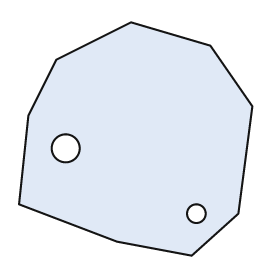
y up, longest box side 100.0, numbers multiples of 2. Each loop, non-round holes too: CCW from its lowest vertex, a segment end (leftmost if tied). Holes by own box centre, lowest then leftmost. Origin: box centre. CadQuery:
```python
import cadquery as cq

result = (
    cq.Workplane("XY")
    .moveTo(24.0, -50.0)
    .lineTo(44.0, -32.0)
    .lineTo(50.0, 14.0)
    .lineTo(32.0, 40.0)
    .lineTo(-2.0, 50.0)
    .lineTo(-34.0, 34.0)
    .lineTo(-46.0, 10.0)
    .lineTo(-50.0, -28.0)
    .lineTo(-8.0, -44.0)
    .close()
    .moveTo(26.0, -32.0)
    .circle(4.0)
    .moveTo(-30.0, -4.0)
    .circle(6.0)
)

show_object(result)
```